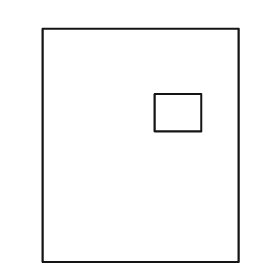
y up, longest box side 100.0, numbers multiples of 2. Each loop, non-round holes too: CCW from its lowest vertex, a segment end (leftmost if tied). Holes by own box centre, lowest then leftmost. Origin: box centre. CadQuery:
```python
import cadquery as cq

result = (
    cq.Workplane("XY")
    .moveTo(-42.0, -50.0)
    .lineTo(42.0, -50.0)
    .lineTo(42.0, 50.0)
    .lineTo(-42.0, 50.0)
    .close()
    .moveTo(6.0, 6.0)
    .lineTo(26.0, 6.0)
    .lineTo(26.0, 22.0)
    .lineTo(6.0, 22.0)
    .close()
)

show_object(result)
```